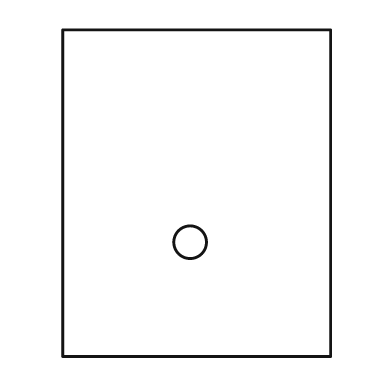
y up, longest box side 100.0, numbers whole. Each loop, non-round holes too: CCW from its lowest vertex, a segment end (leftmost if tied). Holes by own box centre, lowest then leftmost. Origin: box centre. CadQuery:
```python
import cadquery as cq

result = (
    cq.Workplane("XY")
    .moveTo(-41.0, -50.0)
    .lineTo(41.0, -50.0)
    .lineTo(41.0, 50.0)
    .lineTo(-41.0, 50.0)
    .close()
    .moveTo(-2.0, -15.0)
    .circle(5.0)
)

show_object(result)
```